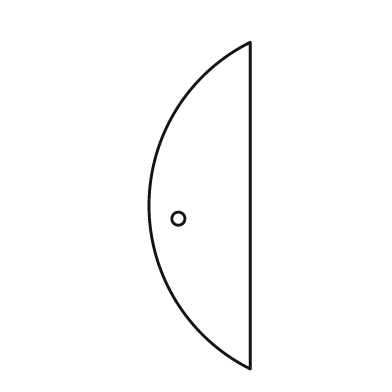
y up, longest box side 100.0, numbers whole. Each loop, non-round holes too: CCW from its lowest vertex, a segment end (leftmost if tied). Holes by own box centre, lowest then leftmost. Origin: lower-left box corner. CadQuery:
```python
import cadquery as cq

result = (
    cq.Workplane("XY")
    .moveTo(31.0, 0.0)
    .lineTo(31.0, 100.0)
    .threePointArc((0.0, 50.0), (31.0, 0.0))
    .close()
    .moveTo(9.0, 46.0)
    .circle(2.0)
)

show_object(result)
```